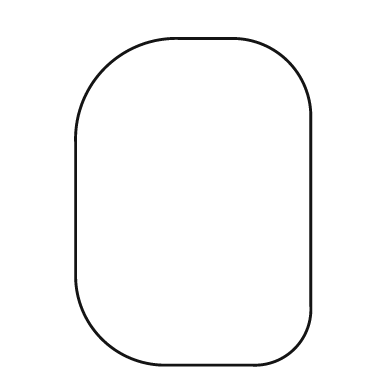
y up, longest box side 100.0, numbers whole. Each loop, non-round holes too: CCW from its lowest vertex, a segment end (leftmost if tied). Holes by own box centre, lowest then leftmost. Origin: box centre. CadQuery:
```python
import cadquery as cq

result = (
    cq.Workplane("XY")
    .moveTo(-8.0, -50.0)
    .lineTo(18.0, -50.0)
    .threePointArc((31.0, -45.0), (36.0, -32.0))
    .lineTo(36.0, 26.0)
    .threePointArc((29.0, 43.0), (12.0, 50.0))
    .lineTo(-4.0, 50.0)
    .threePointArc((-27.0, 41.0), (-36.0, 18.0))
    .lineTo(-36.0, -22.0)
    .threePointArc((-28.0, -42.0), (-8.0, -50.0))
    .close()
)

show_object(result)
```